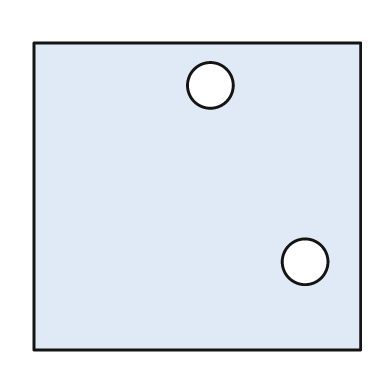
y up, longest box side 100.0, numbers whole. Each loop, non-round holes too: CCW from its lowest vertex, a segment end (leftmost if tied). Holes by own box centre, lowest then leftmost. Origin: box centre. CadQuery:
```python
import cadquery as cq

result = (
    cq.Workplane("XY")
    .moveTo(-50.0, -47.0)
    .lineTo(50.0, -47.0)
    .lineTo(50.0, 47.0)
    .lineTo(-50.0, 47.0)
    .close()
    .moveTo(33.0, -20.0)
    .circle(7.0)
    .moveTo(4.0, 34.0)
    .circle(7.0)
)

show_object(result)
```